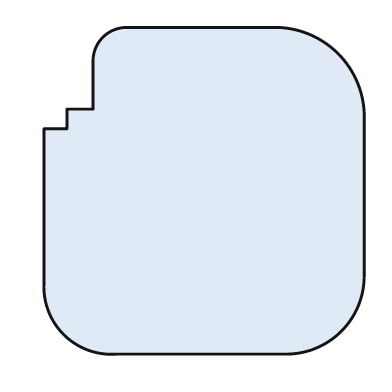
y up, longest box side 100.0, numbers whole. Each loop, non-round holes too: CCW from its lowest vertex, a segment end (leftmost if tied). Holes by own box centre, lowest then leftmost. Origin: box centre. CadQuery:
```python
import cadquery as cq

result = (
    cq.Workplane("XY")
    .moveTo(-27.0, -50.0)
    .lineTo(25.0, -50.0)
    .threePointArc((42.0, -43.0), (49.0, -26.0))
    .lineTo(49.0, 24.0)
    .threePointArc((41.0, 42.0), (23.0, 50.0))
    .lineTo(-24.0, 50.0)
    .threePointArc((-31.0, 47.0), (-34.0, 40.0))
    .lineTo(-34.0, 25.0)
    .lineTo(-42.0, 25.0)
    .lineTo(-42.0, 19.0)
    .lineTo(-49.0, 19.0)
    .lineTo(-49.0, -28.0)
    .threePointArc((-43.0, -44.0), (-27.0, -50.0))
    .close()
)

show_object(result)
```